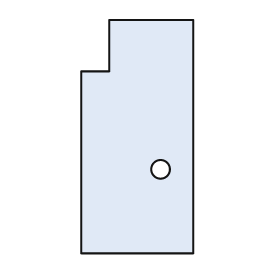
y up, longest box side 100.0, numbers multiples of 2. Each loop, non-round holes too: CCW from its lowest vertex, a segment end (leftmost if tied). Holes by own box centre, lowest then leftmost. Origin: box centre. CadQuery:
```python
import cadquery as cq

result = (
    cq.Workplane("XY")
    .moveTo(-24.0, -50.0)
    .lineTo(24.0, -50.0)
    .lineTo(24.0, 50.0)
    .lineTo(-12.0, 50.0)
    .lineTo(-12.0, 28.0)
    .lineTo(-24.0, 28.0)
    .close()
    .moveTo(10.0, -14.0)
    .circle(4.0)
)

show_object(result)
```